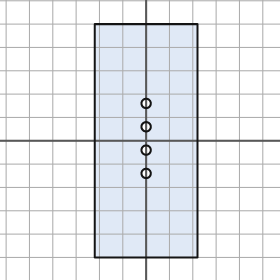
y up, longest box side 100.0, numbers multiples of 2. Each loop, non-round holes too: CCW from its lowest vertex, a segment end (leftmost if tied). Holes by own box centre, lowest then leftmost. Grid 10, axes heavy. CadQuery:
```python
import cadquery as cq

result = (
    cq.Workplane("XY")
    .moveTo(-22.0, -50.0)
    .lineTo(22.0, -50.0)
    .lineTo(22.0, 50.0)
    .lineTo(-22.0, 50.0)
    .close()
    .moveTo(0.0, -14.0)
    .circle(2.0)
    .moveTo(0.0, -4.0)
    .circle(2.0)
    .moveTo(0.0, 6.0)
    .circle(2.0)
    .moveTo(0.0, 16.0)
    .circle(2.0)
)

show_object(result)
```